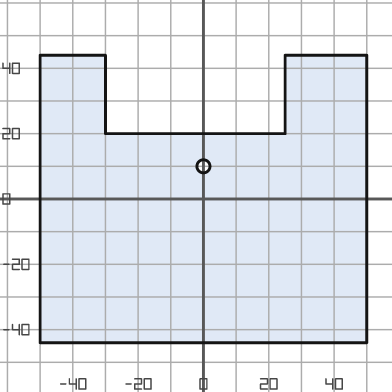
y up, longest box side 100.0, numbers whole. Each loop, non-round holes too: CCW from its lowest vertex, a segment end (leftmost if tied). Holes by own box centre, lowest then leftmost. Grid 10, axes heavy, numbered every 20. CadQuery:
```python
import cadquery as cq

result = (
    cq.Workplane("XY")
    .moveTo(-50.0, -44.0)
    .lineTo(50.0, -44.0)
    .lineTo(50.0, 44.0)
    .lineTo(25.0, 44.0)
    .lineTo(25.0, 20.0)
    .lineTo(-30.0, 20.0)
    .lineTo(-30.0, 44.0)
    .lineTo(-50.0, 44.0)
    .close()
    .moveTo(0.0, 10.0)
    .circle(2.0)
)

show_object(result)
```